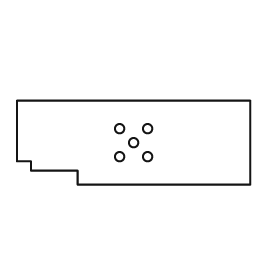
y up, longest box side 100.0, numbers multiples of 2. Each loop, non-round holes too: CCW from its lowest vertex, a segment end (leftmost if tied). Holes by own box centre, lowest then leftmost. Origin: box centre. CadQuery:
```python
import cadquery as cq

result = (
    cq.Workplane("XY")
    .moveTo(-24.0, -18.0)
    .lineTo(50.0, -18.0)
    .lineTo(50.0, 18.0)
    .lineTo(-50.0, 18.0)
    .lineTo(-50.0, -8.0)
    .lineTo(-44.0, -8.0)
    .lineTo(-44.0, -12.0)
    .lineTo(-24.0, -12.0)
    .close()
    .moveTo(-6.0, -6.0)
    .circle(2.0)
    .moveTo(6.0, -6.0)
    .circle(2.0)
    .moveTo(0.0, 0.0)
    .circle(2.0)
    .moveTo(-6.0, 6.0)
    .circle(2.0)
    .moveTo(6.0, 6.0)
    .circle(2.0)
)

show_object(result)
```